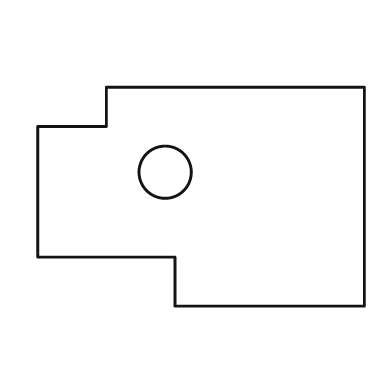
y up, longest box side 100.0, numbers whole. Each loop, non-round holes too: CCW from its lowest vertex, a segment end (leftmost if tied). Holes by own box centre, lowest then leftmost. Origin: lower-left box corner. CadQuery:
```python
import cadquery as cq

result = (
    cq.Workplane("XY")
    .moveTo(42.0, 0.0)
    .lineTo(100.0, 0.0)
    .lineTo(100.0, 67.0)
    .lineTo(21.0, 67.0)
    .lineTo(21.0, 55.0)
    .lineTo(0.0, 55.0)
    .lineTo(0.0, 15.0)
    .lineTo(42.0, 15.0)
    .close()
    .moveTo(39.0, 41.0)
    .circle(8.0)
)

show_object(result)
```